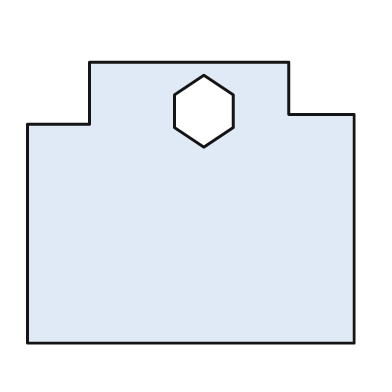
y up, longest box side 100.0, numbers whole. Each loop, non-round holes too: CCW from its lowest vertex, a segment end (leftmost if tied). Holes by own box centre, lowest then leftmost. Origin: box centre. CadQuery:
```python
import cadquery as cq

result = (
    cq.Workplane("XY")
    .moveTo(-50.0, -43.0)
    .lineTo(50.0, -43.0)
    .lineTo(50.0, 27.0)
    .lineTo(30.0, 27.0)
    .lineTo(30.0, 43.0)
    .lineTo(-31.0, 43.0)
    .lineTo(-31.0, 24.0)
    .lineTo(-50.0, 24.0)
    .close()
    .moveTo(4.0, 17.0)
    .lineTo(13.0, 23.0)
    .lineTo(13.0, 33.0)
    .lineTo(4.0, 39.0)
    .lineTo(-5.0, 33.0)
    .lineTo(-5.0, 23.0)
    .close()
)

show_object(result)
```